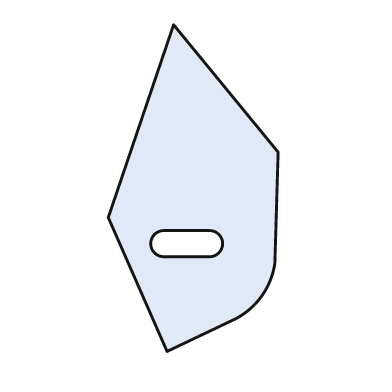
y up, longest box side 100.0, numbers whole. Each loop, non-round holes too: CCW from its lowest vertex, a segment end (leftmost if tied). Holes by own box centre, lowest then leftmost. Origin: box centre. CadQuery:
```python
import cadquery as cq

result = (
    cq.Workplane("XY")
    .moveTo(-8.0, -50.0)
    .lineTo(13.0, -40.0)
    .threePointArc((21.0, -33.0), (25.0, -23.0))
    .lineTo(26.0, 11.0)
    .lineTo(-6.0, 50.0)
    .lineTo(-26.0, -9.0)
    .close()
    .moveTo(-9.0, -21.0)
    .lineTo(5.0, -21.0)
    .threePointArc((9.0, -17.0), (5.0, -13.0))
    .lineTo(-9.0, -13.0)
    .threePointArc((-13.0, -17.0), (-9.0, -21.0))
    .close()
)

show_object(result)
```